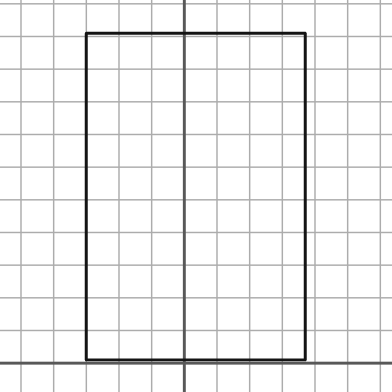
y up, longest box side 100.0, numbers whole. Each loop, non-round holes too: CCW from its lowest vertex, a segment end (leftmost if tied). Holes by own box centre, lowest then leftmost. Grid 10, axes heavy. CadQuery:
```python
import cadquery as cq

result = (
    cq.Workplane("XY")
    .moveTo(-30.0, 1.0)
    .lineTo(37.0, 1.0)
    .lineTo(37.0, 101.0)
    .lineTo(-30.0, 101.0)
    .close()
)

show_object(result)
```